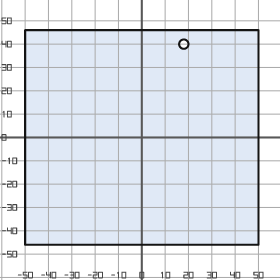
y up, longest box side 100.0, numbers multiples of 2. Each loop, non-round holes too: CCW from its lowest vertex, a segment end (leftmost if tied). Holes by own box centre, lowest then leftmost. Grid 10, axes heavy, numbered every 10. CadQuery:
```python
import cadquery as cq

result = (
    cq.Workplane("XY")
    .moveTo(-50.0, -46.0)
    .lineTo(50.0, -46.0)
    .lineTo(50.0, 46.0)
    .lineTo(-50.0, 46.0)
    .close()
    .moveTo(18.0, 40.0)
    .circle(2.0)
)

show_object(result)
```